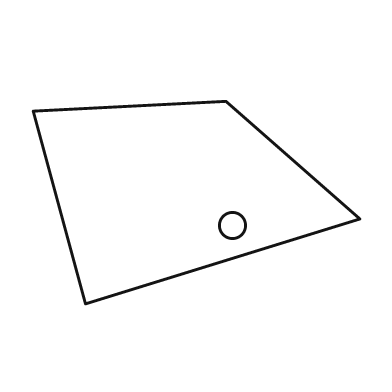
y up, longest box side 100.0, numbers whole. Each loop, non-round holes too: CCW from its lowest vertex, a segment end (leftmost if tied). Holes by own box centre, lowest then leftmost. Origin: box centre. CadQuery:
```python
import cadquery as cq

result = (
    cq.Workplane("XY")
    .moveTo(-34.0, -31.0)
    .lineTo(50.0, -5.0)
    .lineTo(9.0, 31.0)
    .lineTo(-50.0, 28.0)
    .close()
    .moveTo(11.0, -7.0)
    .circle(4.0)
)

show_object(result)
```